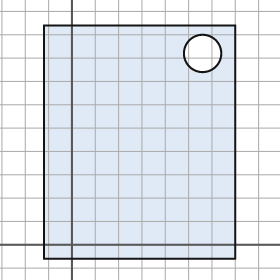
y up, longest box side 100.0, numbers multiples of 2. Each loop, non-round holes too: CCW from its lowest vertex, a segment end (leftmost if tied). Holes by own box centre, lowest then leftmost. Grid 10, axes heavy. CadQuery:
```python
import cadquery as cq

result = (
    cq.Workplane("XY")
    .moveTo(-12.0, -6.0)
    .lineTo(70.0, -6.0)
    .lineTo(70.0, 94.0)
    .lineTo(-12.0, 94.0)
    .close()
    .moveTo(56.0, 82.0)
    .circle(8.0)
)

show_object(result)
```